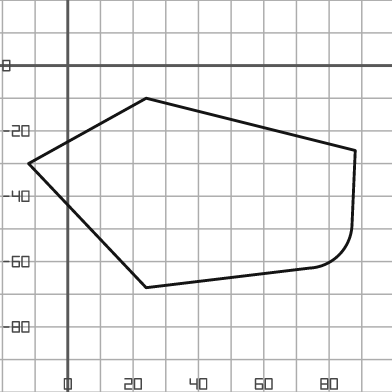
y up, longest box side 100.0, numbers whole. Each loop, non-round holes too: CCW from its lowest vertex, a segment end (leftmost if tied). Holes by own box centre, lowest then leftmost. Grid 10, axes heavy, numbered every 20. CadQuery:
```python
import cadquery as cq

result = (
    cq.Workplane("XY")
    .moveTo(24.0, -68.0)
    .lineTo(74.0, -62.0)
    .threePointArc((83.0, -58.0), (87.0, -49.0))
    .lineTo(88.0, -26.0)
    .lineTo(24.0, -10.0)
    .lineTo(-12.0, -30.0)
    .close()
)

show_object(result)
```